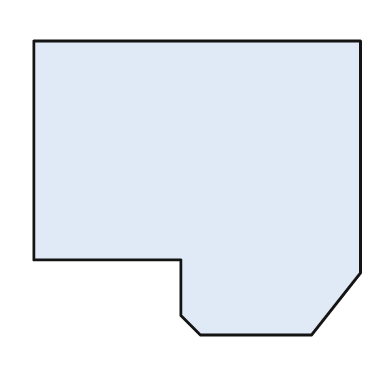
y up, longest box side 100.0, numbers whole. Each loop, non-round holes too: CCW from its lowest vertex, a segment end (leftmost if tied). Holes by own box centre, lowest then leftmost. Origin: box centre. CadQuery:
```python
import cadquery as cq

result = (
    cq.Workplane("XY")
    .moveTo(1.0, -45.0)
    .lineTo(35.0, -45.0)
    .lineTo(50.0, -26.0)
    .lineTo(50.0, 45.0)
    .lineTo(-50.0, 45.0)
    .lineTo(-50.0, -22.0)
    .lineTo(-5.0, -22.0)
    .lineTo(-5.0, -39.0)
    .close()
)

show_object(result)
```